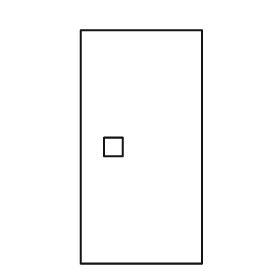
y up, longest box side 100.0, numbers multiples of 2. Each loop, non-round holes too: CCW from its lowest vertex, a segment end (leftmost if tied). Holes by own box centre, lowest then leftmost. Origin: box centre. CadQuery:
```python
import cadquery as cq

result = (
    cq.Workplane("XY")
    .moveTo(-26.0, -50.0)
    .lineTo(26.0, -50.0)
    .lineTo(26.0, 50.0)
    .lineTo(-26.0, 50.0)
    .close()
    .moveTo(-16.0, -4.0)
    .lineTo(-8.0, -4.0)
    .lineTo(-8.0, 4.0)
    .lineTo(-16.0, 4.0)
    .close()
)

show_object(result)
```